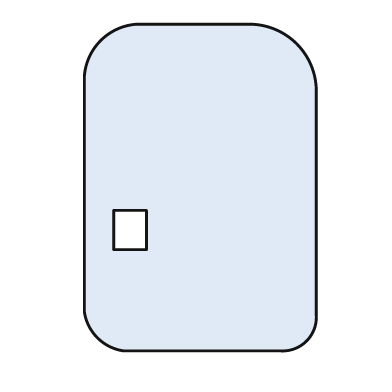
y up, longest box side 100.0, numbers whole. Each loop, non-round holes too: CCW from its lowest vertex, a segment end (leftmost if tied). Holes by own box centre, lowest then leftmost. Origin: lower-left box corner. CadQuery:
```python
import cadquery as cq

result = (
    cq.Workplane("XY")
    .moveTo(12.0, 0.0)
    .lineTo(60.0, 0.0)
    .threePointArc((68.0, 3.0), (71.0, 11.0))
    .lineTo(71.0, 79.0)
    .threePointArc((65.0, 94.0), (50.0, 100.0))
    .lineTo(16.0, 100.0)
    .threePointArc((5.0, 95.0), (0.0, 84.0))
    .lineTo(0.0, 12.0)
    .threePointArc((4.0, 4.0), (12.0, 0.0))
    .close()
    .moveTo(9.0, 31.0)
    .lineTo(19.0, 31.0)
    .lineTo(19.0, 43.0)
    .lineTo(9.0, 43.0)
    .close()
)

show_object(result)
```